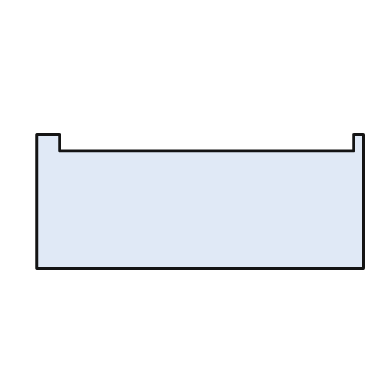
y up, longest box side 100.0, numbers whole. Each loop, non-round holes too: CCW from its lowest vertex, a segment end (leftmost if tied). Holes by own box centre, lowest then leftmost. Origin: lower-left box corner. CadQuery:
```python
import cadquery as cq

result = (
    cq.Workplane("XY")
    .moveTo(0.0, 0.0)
    .lineTo(100.0, 0.0)
    .lineTo(100.0, 41.0)
    .lineTo(97.0, 41.0)
    .lineTo(97.0, 36.0)
    .lineTo(7.0, 36.0)
    .lineTo(7.0, 41.0)
    .lineTo(0.0, 41.0)
    .close()
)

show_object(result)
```